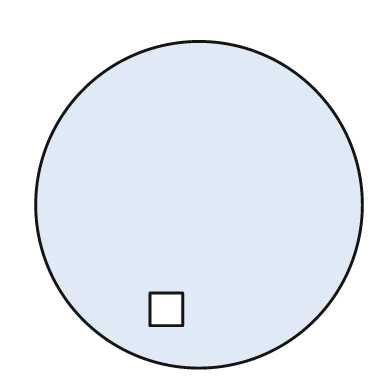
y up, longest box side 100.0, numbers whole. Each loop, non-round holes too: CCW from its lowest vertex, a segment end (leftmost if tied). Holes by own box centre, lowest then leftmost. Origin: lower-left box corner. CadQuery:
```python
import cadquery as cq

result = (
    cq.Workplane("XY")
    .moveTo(50.0, 50.0)
    .circle(50.0)
    .moveTo(35.0, 13.0)
    .lineTo(45.0, 13.0)
    .lineTo(45.0, 23.0)
    .lineTo(35.0, 23.0)
    .close()
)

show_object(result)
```